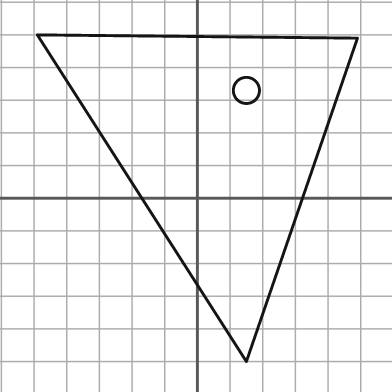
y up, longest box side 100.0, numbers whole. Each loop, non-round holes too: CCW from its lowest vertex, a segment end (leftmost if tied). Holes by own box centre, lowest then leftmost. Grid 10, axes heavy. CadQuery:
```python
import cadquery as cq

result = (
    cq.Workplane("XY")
    .moveTo(15.0, -50.0)
    .lineTo(49.0, 49.0)
    .lineTo(-49.0, 50.0)
    .close()
    .moveTo(15.0, 33.0)
    .circle(4.0)
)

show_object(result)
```